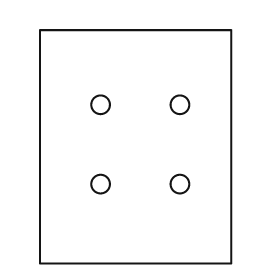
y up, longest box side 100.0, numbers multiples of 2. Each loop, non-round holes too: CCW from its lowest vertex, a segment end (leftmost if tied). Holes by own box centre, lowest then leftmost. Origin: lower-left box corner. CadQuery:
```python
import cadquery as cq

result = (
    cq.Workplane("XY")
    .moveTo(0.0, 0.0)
    .lineTo(82.0, 0.0)
    .lineTo(82.0, 100.0)
    .lineTo(0.0, 100.0)
    .close()
    .moveTo(26.0, 34.0)
    .circle(4.0)
    .moveTo(60.0, 34.0)
    .circle(4.0)
    .moveTo(26.0, 68.0)
    .circle(4.0)
    .moveTo(60.0, 68.0)
    .circle(4.0)
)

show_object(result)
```